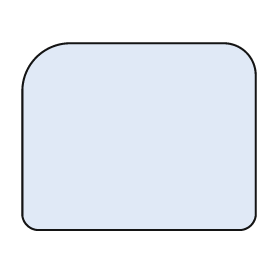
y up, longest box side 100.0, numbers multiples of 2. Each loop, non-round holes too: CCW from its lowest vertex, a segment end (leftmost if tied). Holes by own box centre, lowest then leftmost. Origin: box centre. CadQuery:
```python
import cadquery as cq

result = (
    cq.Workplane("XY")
    .moveTo(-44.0, -40.0)
    .lineTo(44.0, -40.0)
    .threePointArc((48.0, -38.0), (50.0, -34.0))
    .lineTo(50.0, 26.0)
    .threePointArc((46.0, 36.0), (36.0, 40.0))
    .lineTo(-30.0, 40.0)
    .threePointArc((-44.0, 34.0), (-50.0, 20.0))
    .lineTo(-50.0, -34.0)
    .threePointArc((-48.0, -38.0), (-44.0, -40.0))
    .close()
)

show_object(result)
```